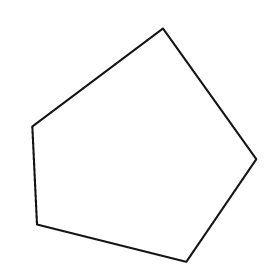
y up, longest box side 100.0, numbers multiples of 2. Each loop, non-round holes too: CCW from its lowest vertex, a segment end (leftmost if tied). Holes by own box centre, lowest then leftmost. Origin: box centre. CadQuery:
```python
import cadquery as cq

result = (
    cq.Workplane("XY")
    .moveTo(18.0, -50.0)
    .lineTo(48.0, -6.0)
    .lineTo(8.0, 50.0)
    .lineTo(-48.0, 8.0)
    .lineTo(-46.0, -34.0)
    .close()
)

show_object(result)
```